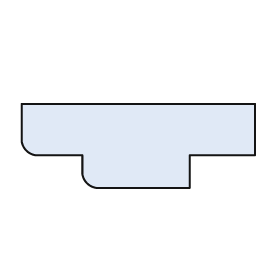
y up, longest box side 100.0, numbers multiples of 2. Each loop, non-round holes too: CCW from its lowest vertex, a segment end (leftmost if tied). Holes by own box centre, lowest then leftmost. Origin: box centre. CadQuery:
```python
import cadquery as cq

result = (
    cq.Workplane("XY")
    .moveTo(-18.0, -18.0)
    .lineTo(22.0, -18.0)
    .lineTo(22.0, -4.0)
    .lineTo(50.0, -4.0)
    .lineTo(50.0, 18.0)
    .lineTo(-50.0, 18.0)
    .lineTo(-50.0, 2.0)
    .threePointArc((-48.0, -2.0), (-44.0, -4.0))
    .lineTo(-24.0, -4.0)
    .lineTo(-24.0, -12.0)
    .threePointArc((-22.0, -16.0), (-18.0, -18.0))
    .close()
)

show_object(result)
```